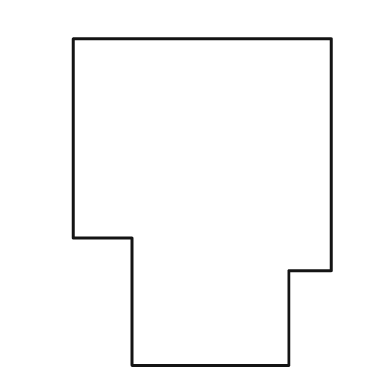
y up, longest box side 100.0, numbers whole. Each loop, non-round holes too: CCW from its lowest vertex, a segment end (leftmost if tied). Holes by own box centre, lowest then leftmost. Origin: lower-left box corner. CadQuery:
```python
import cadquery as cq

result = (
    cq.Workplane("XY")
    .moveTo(18.0, 0.0)
    .lineTo(66.0, 0.0)
    .lineTo(66.0, 29.0)
    .lineTo(79.0, 29.0)
    .lineTo(79.0, 100.0)
    .lineTo(0.0, 100.0)
    .lineTo(0.0, 39.0)
    .lineTo(18.0, 39.0)
    .close()
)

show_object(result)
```